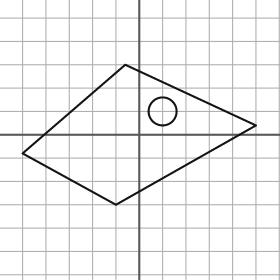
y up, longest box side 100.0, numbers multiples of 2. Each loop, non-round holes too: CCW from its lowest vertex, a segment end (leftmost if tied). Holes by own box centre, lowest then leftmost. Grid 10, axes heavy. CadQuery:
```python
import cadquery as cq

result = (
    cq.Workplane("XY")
    .moveTo(-10.0, -30.0)
    .lineTo(50.0, 4.0)
    .lineTo(-6.0, 30.0)
    .lineTo(-50.0, -8.0)
    .close()
    .moveTo(10.0, 10.0)
    .circle(6.0)
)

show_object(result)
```